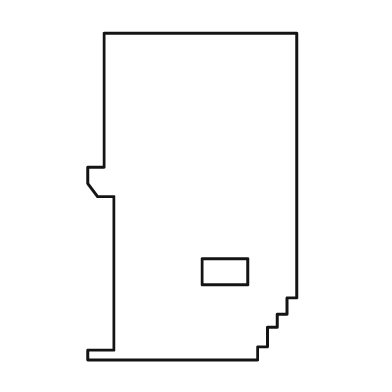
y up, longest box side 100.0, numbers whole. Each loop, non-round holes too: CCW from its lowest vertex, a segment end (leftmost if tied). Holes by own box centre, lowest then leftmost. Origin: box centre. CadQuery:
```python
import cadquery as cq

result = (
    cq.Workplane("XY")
    .moveTo(-32.0, -50.0)
    .lineTo(20.0, -50.0)
    .lineTo(20.0, -46.0)
    .lineTo(23.0, -46.0)
    .lineTo(23.0, -40.0)
    .lineTo(26.0, -40.0)
    .lineTo(26.0, -36.0)
    .lineTo(29.0, -36.0)
    .lineTo(29.0, -31.0)
    .lineTo(32.0, -31.0)
    .lineTo(32.0, 50.0)
    .lineTo(-27.0, 50.0)
    .lineTo(-27.0, 9.0)
    .lineTo(-32.0, 9.0)
    .lineTo(-32.0, 4.0)
    .lineTo(-29.0, 0.0)
    .lineTo(-24.0, 0.0)
    .lineTo(-24.0, -47.0)
    .lineTo(-32.0, -47.0)
    .close()
    .moveTo(3.0, -27.0)
    .lineTo(17.0, -27.0)
    .lineTo(17.0, -19.0)
    .lineTo(3.0, -19.0)
    .close()
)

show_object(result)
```